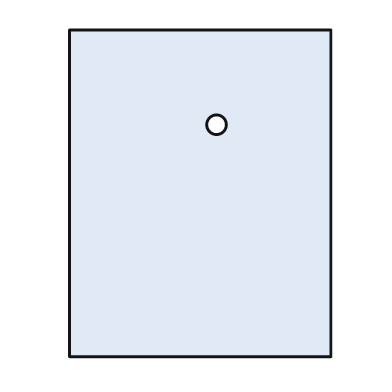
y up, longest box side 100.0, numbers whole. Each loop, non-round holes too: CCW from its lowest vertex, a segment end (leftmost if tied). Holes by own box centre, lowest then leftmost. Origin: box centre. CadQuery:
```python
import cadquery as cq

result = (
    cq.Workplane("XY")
    .moveTo(-40.0, -50.0)
    .lineTo(40.0, -50.0)
    .lineTo(40.0, 50.0)
    .lineTo(-40.0, 50.0)
    .close()
    .moveTo(5.0, 21.0)
    .circle(3.0)
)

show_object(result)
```